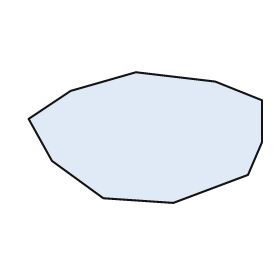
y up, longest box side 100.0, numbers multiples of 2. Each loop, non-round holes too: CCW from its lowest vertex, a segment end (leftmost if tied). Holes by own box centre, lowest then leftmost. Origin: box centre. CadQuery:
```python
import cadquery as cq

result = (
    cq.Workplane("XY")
    .moveTo(12.0, -28.0)
    .lineTo(44.0, -16.0)
    .lineTo(50.0, -2.0)
    .lineTo(50.0, 16.0)
    .lineTo(30.0, 24.0)
    .lineTo(-4.0, 28.0)
    .lineTo(-32.0, 20.0)
    .lineTo(-50.0, 8.0)
    .lineTo(-40.0, -10.0)
    .lineTo(-18.0, -26.0)
    .close()
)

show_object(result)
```